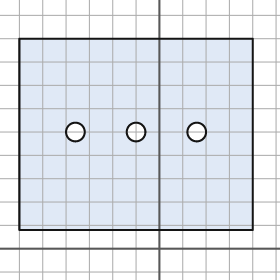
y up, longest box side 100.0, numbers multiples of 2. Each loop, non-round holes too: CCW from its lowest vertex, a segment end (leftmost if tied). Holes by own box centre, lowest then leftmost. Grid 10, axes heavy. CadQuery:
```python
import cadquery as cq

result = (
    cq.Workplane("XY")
    .moveTo(-60.0, 8.0)
    .lineTo(40.0, 8.0)
    .lineTo(40.0, 90.0)
    .lineTo(-60.0, 90.0)
    .close()
    .moveTo(-36.0, 50.0)
    .circle(4.0)
    .moveTo(-10.0, 50.0)
    .circle(4.0)
    .moveTo(16.0, 50.0)
    .circle(4.0)
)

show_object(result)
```